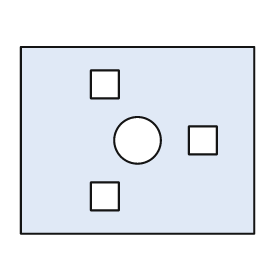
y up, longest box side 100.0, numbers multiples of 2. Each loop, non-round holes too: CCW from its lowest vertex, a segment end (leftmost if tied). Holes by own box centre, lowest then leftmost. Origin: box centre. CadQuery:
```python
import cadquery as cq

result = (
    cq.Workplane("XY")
    .moveTo(-50.0, -40.0)
    .lineTo(50.0, -40.0)
    .lineTo(50.0, 40.0)
    .lineTo(-50.0, 40.0)
    .close()
    .moveTo(-20.0, -30.0)
    .lineTo(-8.0, -30.0)
    .lineTo(-8.0, -18.0)
    .lineTo(-20.0, -18.0)
    .close()
    .moveTo(0.0, 0.0)
    .circle(10.0)
    .moveTo(22.0, -6.0)
    .lineTo(34.0, -6.0)
    .lineTo(34.0, 6.0)
    .lineTo(22.0, 6.0)
    .close()
    .moveTo(-20.0, 18.0)
    .lineTo(-8.0, 18.0)
    .lineTo(-8.0, 30.0)
    .lineTo(-20.0, 30.0)
    .close()
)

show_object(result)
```